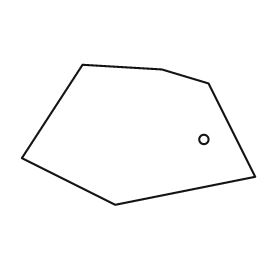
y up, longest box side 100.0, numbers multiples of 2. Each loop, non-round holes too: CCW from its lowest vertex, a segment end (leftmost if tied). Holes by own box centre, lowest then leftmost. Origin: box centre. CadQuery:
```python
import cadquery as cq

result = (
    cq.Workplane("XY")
    .moveTo(-10.0, -30.0)
    .lineTo(50.0, -18.0)
    .lineTo(30.0, 22.0)
    .lineTo(10.0, 28.0)
    .lineTo(-24.0, 30.0)
    .lineTo(-50.0, -10.0)
    .close()
    .moveTo(28.0, -2.0)
    .circle(2.0)
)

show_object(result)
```